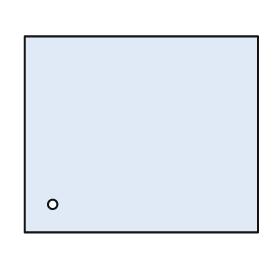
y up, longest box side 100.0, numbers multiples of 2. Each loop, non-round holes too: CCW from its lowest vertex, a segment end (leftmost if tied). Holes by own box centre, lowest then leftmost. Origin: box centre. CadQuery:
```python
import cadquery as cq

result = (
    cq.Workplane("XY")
    .moveTo(-50.0, -42.0)
    .lineTo(50.0, -42.0)
    .lineTo(50.0, 42.0)
    .lineTo(-50.0, 42.0)
    .close()
    .moveTo(-38.0, -30.0)
    .circle(2.0)
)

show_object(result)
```